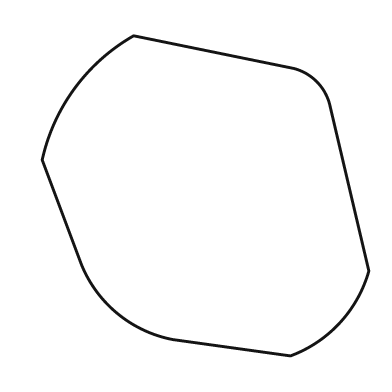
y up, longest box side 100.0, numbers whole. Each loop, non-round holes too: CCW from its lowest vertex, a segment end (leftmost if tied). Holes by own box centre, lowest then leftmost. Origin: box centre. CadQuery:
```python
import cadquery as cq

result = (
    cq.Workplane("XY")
    .moveTo(26.0, -49.0)
    .threePointArc((41.0, -39.0), (50.0, -23.0))
    .lineTo(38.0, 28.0)
    .threePointArc((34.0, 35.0), (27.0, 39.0))
    .lineTo(-22.0, 49.0)
    .threePointArc((-40.0, 33.0), (-50.0, 11.0))
    .lineTo(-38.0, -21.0)
    .threePointArc((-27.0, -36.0), (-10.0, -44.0))
    .close()
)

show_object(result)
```